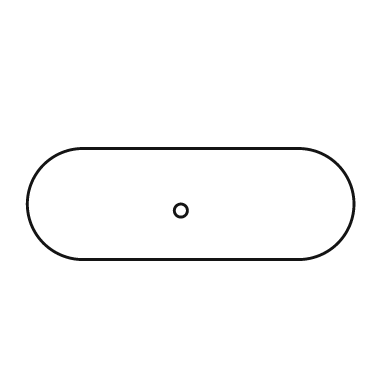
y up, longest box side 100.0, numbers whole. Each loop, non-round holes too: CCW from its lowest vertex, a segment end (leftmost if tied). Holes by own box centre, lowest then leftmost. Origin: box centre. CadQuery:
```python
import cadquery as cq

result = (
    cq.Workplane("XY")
    .moveTo(-33.0, -17.0)
    .lineTo(33.0, -17.0)
    .threePointArc((50.0, 0.0), (33.0, 17.0))
    .lineTo(-33.0, 17.0)
    .threePointArc((-50.0, 0.0), (-33.0, -17.0))
    .close()
    .moveTo(-3.0, -2.0)
    .circle(2.0)
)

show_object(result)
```